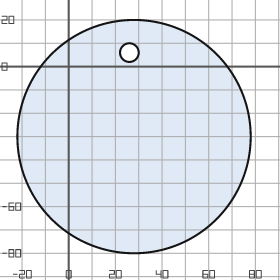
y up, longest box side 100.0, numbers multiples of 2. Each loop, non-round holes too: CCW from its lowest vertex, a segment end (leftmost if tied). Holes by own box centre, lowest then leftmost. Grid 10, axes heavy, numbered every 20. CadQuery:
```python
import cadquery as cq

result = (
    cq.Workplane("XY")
    .moveTo(28.0, -30.0)
    .circle(50.0)
    .moveTo(26.0, 6.0)
    .circle(4.0)
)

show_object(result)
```